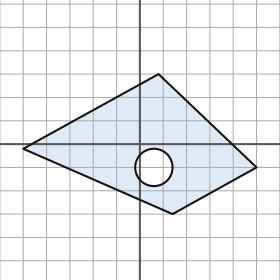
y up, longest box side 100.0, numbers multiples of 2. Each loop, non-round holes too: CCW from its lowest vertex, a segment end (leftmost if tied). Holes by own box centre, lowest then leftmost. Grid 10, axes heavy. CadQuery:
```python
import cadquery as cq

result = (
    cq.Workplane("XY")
    .moveTo(14.0, -30.0)
    .lineTo(50.0, -10.0)
    .lineTo(8.0, 30.0)
    .lineTo(-50.0, -2.0)
    .close()
    .moveTo(6.0, -10.0)
    .circle(8.0)
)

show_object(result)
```